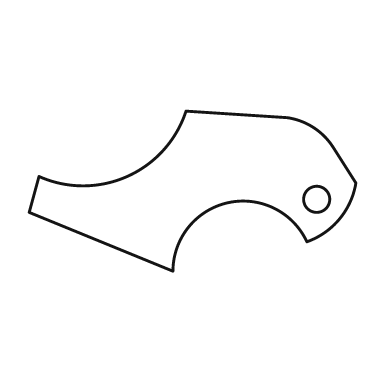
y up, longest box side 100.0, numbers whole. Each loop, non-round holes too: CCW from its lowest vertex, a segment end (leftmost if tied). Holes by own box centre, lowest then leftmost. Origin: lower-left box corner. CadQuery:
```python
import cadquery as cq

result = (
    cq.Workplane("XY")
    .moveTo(44.0, 0.0)
    .threePointArc((61.0, 21.0), (85.0, 9.0))
    .threePointArc((95.0, 16.0), (100.0, 27.0))
    .lineTo(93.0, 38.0)
    .threePointArc((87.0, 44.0), (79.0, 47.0))
    .lineTo(48.0, 49.0)
    .threePointArc((30.0, 29.0), (3.0, 29.0))
    .lineTo(0.0, 18.0)
    .close()
    .moveTo(88.0, 22.0)
    .circle(4.0)
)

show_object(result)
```